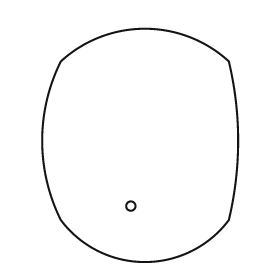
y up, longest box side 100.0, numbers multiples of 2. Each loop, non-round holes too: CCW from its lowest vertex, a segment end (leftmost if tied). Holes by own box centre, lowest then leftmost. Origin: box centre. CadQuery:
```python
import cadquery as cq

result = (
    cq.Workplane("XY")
    .moveTo(-34.0, -32.0)
    .threePointArc((2.0, -50.0), (38.0, -32.0))
    .threePointArc((42.0, 2.0), (38.0, 36.0))
    .threePointArc((2.0, 50.0), (-34.0, 36.0))
    .threePointArc((-42.0, 2.0), (-34.0, -32.0))
    .close()
    .moveTo(-4.0, -26.0)
    .circle(2.0)
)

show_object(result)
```